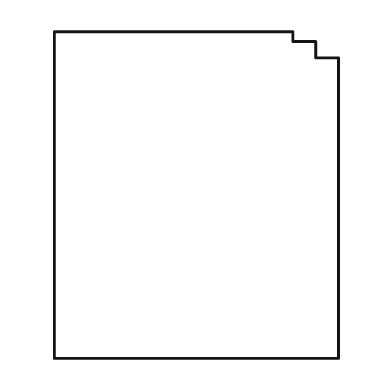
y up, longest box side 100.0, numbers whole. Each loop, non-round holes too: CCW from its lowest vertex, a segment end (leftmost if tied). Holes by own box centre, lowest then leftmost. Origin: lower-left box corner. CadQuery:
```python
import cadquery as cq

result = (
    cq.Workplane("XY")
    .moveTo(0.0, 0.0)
    .lineTo(87.0, 0.0)
    .lineTo(87.0, 92.0)
    .lineTo(80.0, 92.0)
    .lineTo(80.0, 97.0)
    .lineTo(73.0, 97.0)
    .lineTo(73.0, 100.0)
    .lineTo(0.0, 100.0)
    .close()
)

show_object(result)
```